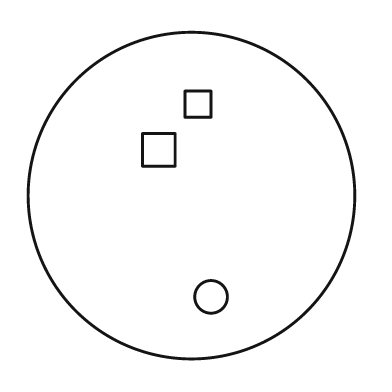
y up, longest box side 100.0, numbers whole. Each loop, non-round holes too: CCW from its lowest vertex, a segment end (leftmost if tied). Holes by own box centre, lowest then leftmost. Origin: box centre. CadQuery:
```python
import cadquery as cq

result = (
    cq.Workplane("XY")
    .moveTo(0.0, 0.0)
    .circle(50.0)
    .moveTo(6.0, -31.0)
    .circle(5.0)
    .moveTo(-15.0, 9.0)
    .lineTo(-5.0, 9.0)
    .lineTo(-5.0, 19.0)
    .lineTo(-15.0, 19.0)
    .close()
    .moveTo(-2.0, 24.0)
    .lineTo(6.0, 24.0)
    .lineTo(6.0, 32.0)
    .lineTo(-2.0, 32.0)
    .close()
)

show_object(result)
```